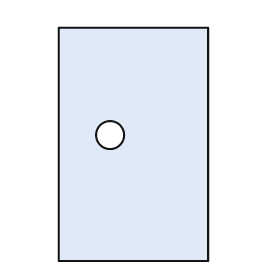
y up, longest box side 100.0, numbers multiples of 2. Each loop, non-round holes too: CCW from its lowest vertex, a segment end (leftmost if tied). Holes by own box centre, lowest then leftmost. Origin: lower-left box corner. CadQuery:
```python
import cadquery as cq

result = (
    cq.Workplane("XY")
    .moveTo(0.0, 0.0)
    .lineTo(64.0, 0.0)
    .lineTo(64.0, 100.0)
    .lineTo(0.0, 100.0)
    .close()
    .moveTo(22.0, 54.0)
    .circle(6.0)
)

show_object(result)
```